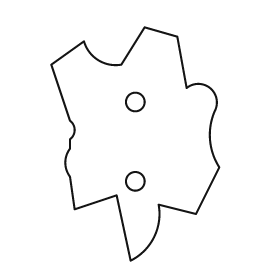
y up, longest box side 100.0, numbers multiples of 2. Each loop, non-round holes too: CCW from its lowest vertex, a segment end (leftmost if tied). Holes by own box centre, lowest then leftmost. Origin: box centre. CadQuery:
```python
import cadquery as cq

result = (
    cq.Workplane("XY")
    .moveTo(-2.0, -50.0)
    .threePointArc((8.0, -40.0), (10.0, -26.0))
    .lineTo(26.0, -30.0)
    .lineTo(36.0, -10.0)
    .threePointArc((32.0, 2.0), (34.0, 14.0))
    .threePointArc((32.0, 24.0), (22.0, 24.0))
    .lineTo(18.0, 46.0)
    .lineTo(4.0, 50.0)
    .lineTo(-6.0, 34.0)
    .threePointArc((-16.0, 36.0), (-22.0, 44.0))
    .lineTo(-36.0, 34.0)
    .lineTo(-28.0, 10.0)
    .threePointArc((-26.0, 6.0), (-28.0, 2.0))
    .lineTo(-28.0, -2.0)
    .threePointArc((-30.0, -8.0), (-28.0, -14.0))
    .lineTo(-26.0, -28.0)
    .lineTo(-8.0, -22.0)
    .close()
    .moveTo(0.0, -16.0)
    .circle(4.0)
    .moveTo(0.0, 18.0)
    .circle(4.0)
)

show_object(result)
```